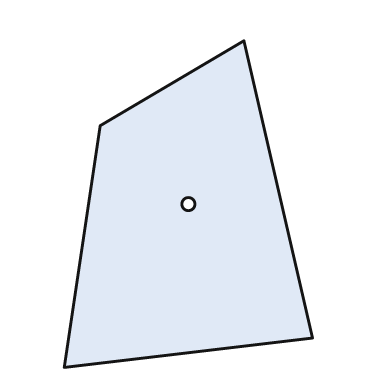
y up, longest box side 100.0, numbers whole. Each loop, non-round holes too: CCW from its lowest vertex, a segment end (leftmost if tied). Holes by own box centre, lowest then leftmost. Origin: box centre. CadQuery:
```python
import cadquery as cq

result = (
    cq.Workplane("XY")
    .moveTo(-38.0, -50.0)
    .lineTo(38.0, -41.0)
    .lineTo(17.0, 50.0)
    .lineTo(-27.0, 24.0)
    .close()
    .moveTo(0.0, 0.0)
    .circle(2.0)
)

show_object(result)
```